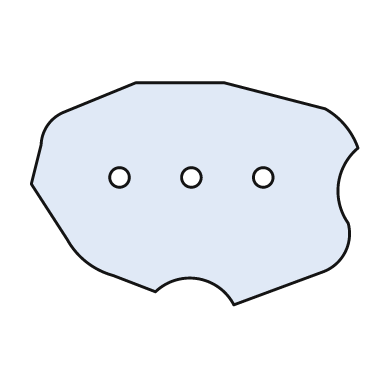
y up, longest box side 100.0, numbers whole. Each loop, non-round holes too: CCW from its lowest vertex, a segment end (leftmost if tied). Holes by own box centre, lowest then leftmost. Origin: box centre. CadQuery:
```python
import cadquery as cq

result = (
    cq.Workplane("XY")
    .moveTo(12.0, -34.0)
    .lineTo(39.0, -24.0)
    .threePointArc((46.0, -18.0), (47.0, -9.0))
    .threePointArc((44.0, 3.0), (50.0, 14.0))
    .threePointArc((46.0, 21.0), (40.0, 26.0))
    .lineTo(9.0, 34.0)
    .lineTo(-18.0, 34.0)
    .lineTo(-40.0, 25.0)
    .threePointArc((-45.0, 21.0), (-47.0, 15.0))
    .lineTo(-50.0, 3.0)
    .lineTo(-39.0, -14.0)
    .threePointArc((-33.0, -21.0), (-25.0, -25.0))
    .lineTo(-12.0, -30.0)
    .threePointArc((1.0, -26.0), (12.0, -34.0))
    .close()
    .moveTo(-23.0, 5.0)
    .circle(3.0)
    .moveTo(-1.0, 5.0)
    .circle(3.0)
    .moveTo(21.0, 5.0)
    .circle(3.0)
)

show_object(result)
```